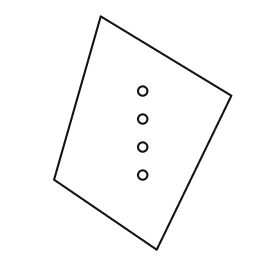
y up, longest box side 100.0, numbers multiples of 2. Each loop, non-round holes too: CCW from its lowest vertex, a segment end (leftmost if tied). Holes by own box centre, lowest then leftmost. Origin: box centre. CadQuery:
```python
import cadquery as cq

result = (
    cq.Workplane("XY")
    .moveTo(6.0, -50.0)
    .lineTo(38.0, 16.0)
    .lineTo(-18.0, 50.0)
    .lineTo(-38.0, -20.0)
    .close()
    .moveTo(0.0, -18.0)
    .circle(2.0)
    .moveTo(0.0, -6.0)
    .circle(2.0)
    .moveTo(0.0, 6.0)
    .circle(2.0)
    .moveTo(0.0, 18.0)
    .circle(2.0)
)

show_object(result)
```